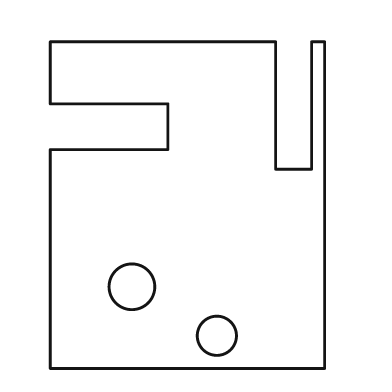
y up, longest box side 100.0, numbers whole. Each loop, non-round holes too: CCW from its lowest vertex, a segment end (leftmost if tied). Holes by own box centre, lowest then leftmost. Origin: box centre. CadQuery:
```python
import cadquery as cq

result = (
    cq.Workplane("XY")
    .moveTo(-42.0, -50.0)
    .lineTo(42.0, -50.0)
    .lineTo(42.0, 50.0)
    .lineTo(38.0, 50.0)
    .lineTo(38.0, 11.0)
    .lineTo(27.0, 11.0)
    .lineTo(27.0, 50.0)
    .lineTo(-42.0, 50.0)
    .lineTo(-42.0, 31.0)
    .lineTo(-6.0, 31.0)
    .lineTo(-6.0, 17.0)
    .lineTo(-42.0, 17.0)
    .close()
    .moveTo(9.0, -40.0)
    .circle(6.0)
    .moveTo(-17.0, -25.0)
    .circle(7.0)
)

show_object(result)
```